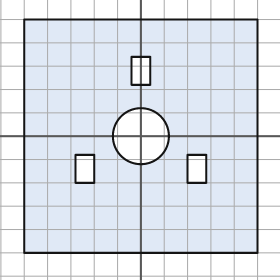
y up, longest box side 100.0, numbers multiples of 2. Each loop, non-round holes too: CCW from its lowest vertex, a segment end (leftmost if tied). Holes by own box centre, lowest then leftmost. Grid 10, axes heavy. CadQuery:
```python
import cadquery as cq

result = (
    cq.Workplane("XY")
    .moveTo(-50.0, -50.0)
    .lineTo(50.0, -50.0)
    .lineTo(50.0, 50.0)
    .lineTo(-50.0, 50.0)
    .close()
    .moveTo(-28.0, -20.0)
    .lineTo(-20.0, -20.0)
    .lineTo(-20.0, -8.0)
    .lineTo(-28.0, -8.0)
    .close()
    .moveTo(20.0, -20.0)
    .lineTo(28.0, -20.0)
    .lineTo(28.0, -8.0)
    .lineTo(20.0, -8.0)
    .close()
    .moveTo(0.0, 0.0)
    .circle(12.0)
    .moveTo(-4.0, 22.0)
    .lineTo(4.0, 22.0)
    .lineTo(4.0, 34.0)
    .lineTo(-4.0, 34.0)
    .close()
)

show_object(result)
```